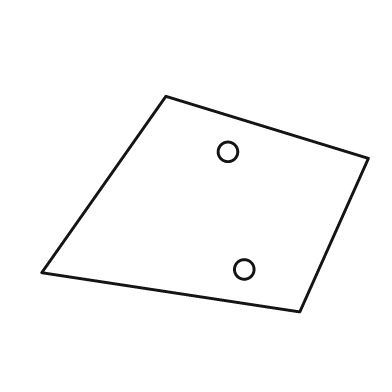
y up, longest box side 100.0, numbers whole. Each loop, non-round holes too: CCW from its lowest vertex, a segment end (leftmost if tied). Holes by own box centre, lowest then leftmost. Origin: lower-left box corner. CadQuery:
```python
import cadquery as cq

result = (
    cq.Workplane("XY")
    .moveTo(79.0, 0.0)
    .lineTo(100.0, 47.0)
    .lineTo(38.0, 66.0)
    .lineTo(0.0, 12.0)
    .close()
    .moveTo(62.0, 13.0)
    .circle(3.0)
    .moveTo(57.0, 49.0)
    .circle(3.0)
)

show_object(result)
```